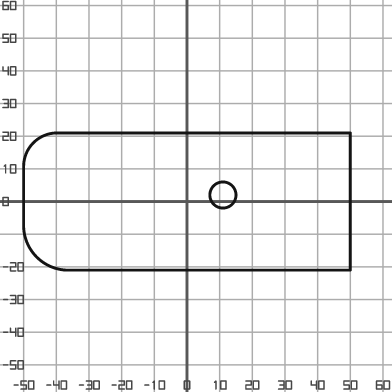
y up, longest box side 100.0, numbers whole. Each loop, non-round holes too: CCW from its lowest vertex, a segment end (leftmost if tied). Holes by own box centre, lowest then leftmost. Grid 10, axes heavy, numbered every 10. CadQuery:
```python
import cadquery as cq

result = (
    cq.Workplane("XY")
    .moveTo(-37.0, -21.0)
    .lineTo(50.0, -21.0)
    .lineTo(50.0, 21.0)
    .lineTo(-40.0, 21.0)
    .threePointArc((-47.0, 18.0), (-50.0, 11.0))
    .lineTo(-50.0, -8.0)
    .threePointArc((-46.0, -17.0), (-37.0, -21.0))
    .close()
    .moveTo(11.0, 2.0)
    .circle(4.0)
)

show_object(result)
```